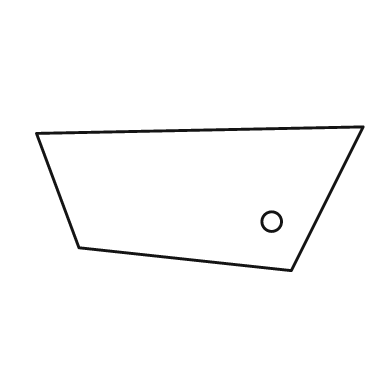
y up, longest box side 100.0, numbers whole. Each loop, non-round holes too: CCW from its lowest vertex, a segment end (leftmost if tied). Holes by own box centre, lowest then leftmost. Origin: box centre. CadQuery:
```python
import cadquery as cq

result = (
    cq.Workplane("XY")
    .moveTo(28.0, -22.0)
    .lineTo(50.0, 22.0)
    .lineTo(-50.0, 20.0)
    .lineTo(-37.0, -15.0)
    .close()
    .moveTo(22.0, -7.0)
    .circle(3.0)
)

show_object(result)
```